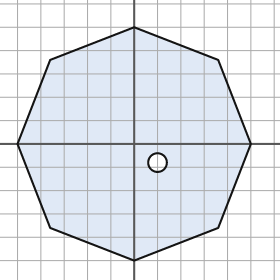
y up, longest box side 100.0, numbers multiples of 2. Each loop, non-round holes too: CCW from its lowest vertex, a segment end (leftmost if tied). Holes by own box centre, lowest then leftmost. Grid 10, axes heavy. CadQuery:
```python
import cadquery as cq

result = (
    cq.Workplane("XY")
    .moveTo(0.0, -50.0)
    .lineTo(36.0, -36.0)
    .lineTo(50.0, 0.0)
    .lineTo(36.0, 36.0)
    .lineTo(0.0, 50.0)
    .lineTo(-36.0, 36.0)
    .lineTo(-50.0, 0.0)
    .lineTo(-36.0, -36.0)
    .close()
    .moveTo(10.0, -8.0)
    .circle(4.0)
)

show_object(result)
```